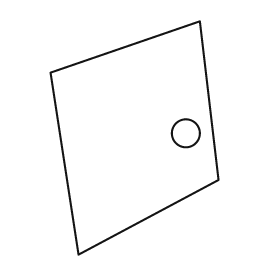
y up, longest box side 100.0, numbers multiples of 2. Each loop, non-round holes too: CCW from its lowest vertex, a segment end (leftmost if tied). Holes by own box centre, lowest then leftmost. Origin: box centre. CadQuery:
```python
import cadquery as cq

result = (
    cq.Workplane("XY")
    .moveTo(-24.0, -50.0)
    .lineTo(36.0, -18.0)
    .lineTo(28.0, 50.0)
    .lineTo(-36.0, 28.0)
    .close()
    .moveTo(22.0, 2.0)
    .circle(6.0)
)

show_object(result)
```